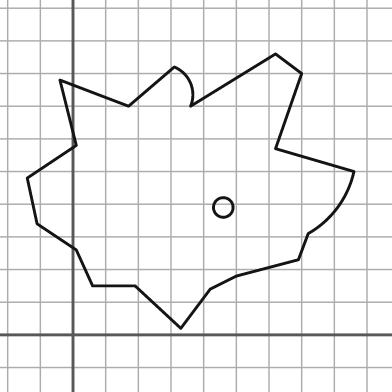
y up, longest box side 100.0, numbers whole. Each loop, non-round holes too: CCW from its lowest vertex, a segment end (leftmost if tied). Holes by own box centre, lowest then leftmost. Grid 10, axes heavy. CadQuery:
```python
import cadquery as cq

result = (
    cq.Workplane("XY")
    .moveTo(33.0, 2.0)
    .lineTo(42.0, 14.0)
    .lineTo(50.0, 18.0)
    .lineTo(69.0, 23.0)
    .lineTo(72.0, 31.0)
    .threePointArc((81.0, 39.0), (86.0, 50.0))
    .lineTo(62.0, 57.0)
    .lineTo(70.0, 80.0)
    .lineTo(62.0, 86.0)
    .lineTo(36.0, 70.0)
    .threePointArc((36.0, 77.0), (31.0, 82.0))
    .lineTo(17.0, 70.0)
    .lineTo(-4.0, 78.0)
    .lineTo(1.0, 58.0)
    .lineTo(-14.0, 48.0)
    .lineTo(-11.0, 34.0)
    .lineTo(1.0, 26.0)
    .lineTo(6.0, 15.0)
    .lineTo(19.0, 15.0)
    .close()
    .moveTo(46.0, 39.0)
    .circle(3.0)
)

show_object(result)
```